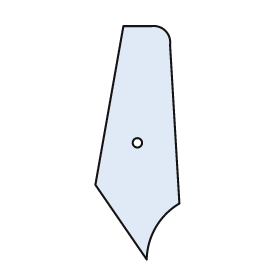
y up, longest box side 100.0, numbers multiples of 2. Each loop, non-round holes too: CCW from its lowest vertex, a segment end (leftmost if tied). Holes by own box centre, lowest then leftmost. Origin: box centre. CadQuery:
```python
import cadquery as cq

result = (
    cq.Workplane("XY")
    .moveTo(4.0, -50.0)
    .threePointArc((8.0, -36.0), (18.0, -26.0))
    .lineTo(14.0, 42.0)
    .threePointArc((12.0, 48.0), (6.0, 50.0))
    .lineTo(-6.0, 50.0)
    .lineTo(-18.0, -18.0)
    .close()
    .moveTo(0.0, 0.0)
    .circle(2.0)
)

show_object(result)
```